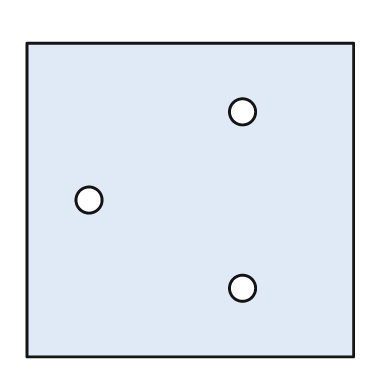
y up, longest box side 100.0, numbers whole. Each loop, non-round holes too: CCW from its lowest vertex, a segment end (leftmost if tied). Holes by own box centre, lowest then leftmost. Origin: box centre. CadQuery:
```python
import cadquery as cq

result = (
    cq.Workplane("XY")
    .moveTo(-50.0, -48.0)
    .lineTo(50.0, -48.0)
    .lineTo(50.0, 48.0)
    .lineTo(-50.0, 48.0)
    .close()
    .moveTo(16.0, -27.0)
    .circle(4.0)
    .moveTo(-31.0, 0.0)
    .circle(4.0)
    .moveTo(16.0, 27.0)
    .circle(4.0)
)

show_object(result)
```